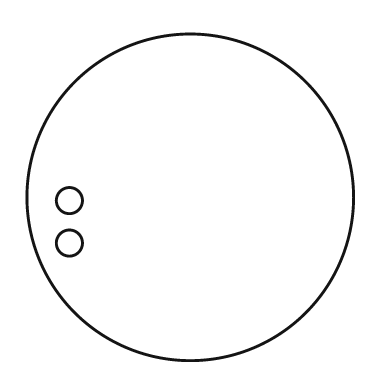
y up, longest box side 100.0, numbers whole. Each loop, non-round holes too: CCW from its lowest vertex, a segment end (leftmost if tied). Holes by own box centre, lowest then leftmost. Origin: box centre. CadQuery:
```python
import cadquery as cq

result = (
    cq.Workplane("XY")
    .moveTo(0.0, 0.0)
    .circle(50.0)
    .moveTo(-37.0, -14.0)
    .circle(4.0)
    .moveTo(-37.0, -1.0)
    .circle(4.0)
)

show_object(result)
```